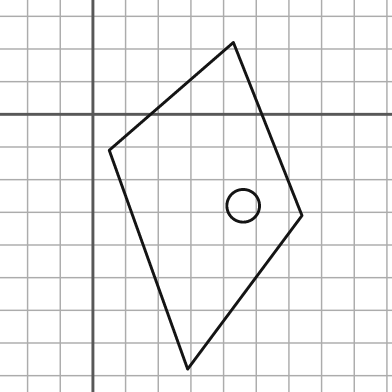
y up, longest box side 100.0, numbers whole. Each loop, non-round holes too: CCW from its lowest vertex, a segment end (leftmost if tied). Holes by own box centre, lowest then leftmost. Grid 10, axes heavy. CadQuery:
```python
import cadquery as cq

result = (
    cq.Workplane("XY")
    .moveTo(29.0, -78.0)
    .lineTo(64.0, -31.0)
    .lineTo(43.0, 22.0)
    .lineTo(5.0, -11.0)
    .close()
    .moveTo(46.0, -28.0)
    .circle(5.0)
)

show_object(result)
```